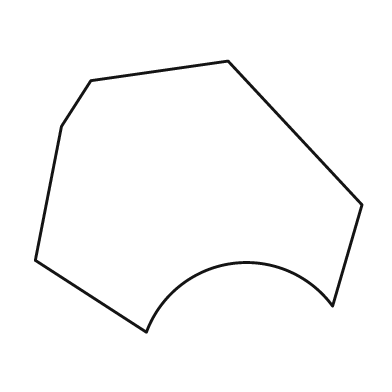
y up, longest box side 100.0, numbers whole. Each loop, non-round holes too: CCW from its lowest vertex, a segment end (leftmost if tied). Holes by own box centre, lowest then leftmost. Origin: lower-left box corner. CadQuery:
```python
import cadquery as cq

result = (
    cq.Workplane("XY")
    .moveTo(34.0, 0.0)
    .threePointArc((60.0, 21.0), (91.0, 8.0))
    .lineTo(100.0, 39.0)
    .lineTo(59.0, 83.0)
    .lineTo(17.0, 77.0)
    .lineTo(8.0, 63.0)
    .lineTo(0.0, 22.0)
    .close()
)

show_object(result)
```